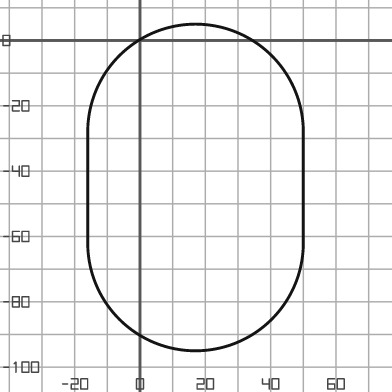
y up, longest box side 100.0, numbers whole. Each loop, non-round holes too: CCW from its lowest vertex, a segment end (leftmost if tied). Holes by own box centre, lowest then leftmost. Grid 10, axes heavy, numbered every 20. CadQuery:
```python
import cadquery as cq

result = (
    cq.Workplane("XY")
    .moveTo(-16.0, -62.0)
    .threePointArc((17.0, -95.0), (50.0, -62.0))
    .lineTo(50.0, -28.0)
    .threePointArc((17.0, 5.0), (-16.0, -28.0))
    .close()
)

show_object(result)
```